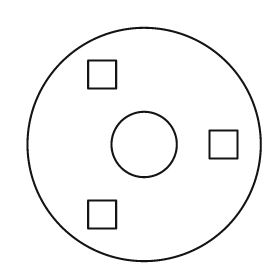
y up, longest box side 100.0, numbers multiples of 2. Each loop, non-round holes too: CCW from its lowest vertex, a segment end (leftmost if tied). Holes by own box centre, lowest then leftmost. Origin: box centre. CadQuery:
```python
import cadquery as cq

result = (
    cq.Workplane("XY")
    .moveTo(0.0, 0.0)
    .circle(50.0)
    .moveTo(-24.0, -36.0)
    .lineTo(-12.0, -36.0)
    .lineTo(-12.0, -24.0)
    .lineTo(-24.0, -24.0)
    .close()
    .moveTo(0.0, 0.0)
    .circle(14.0)
    .moveTo(28.0, -6.0)
    .lineTo(40.0, -6.0)
    .lineTo(40.0, 6.0)
    .lineTo(28.0, 6.0)
    .close()
    .moveTo(-24.0, 24.0)
    .lineTo(-12.0, 24.0)
    .lineTo(-12.0, 36.0)
    .lineTo(-24.0, 36.0)
    .close()
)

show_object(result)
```